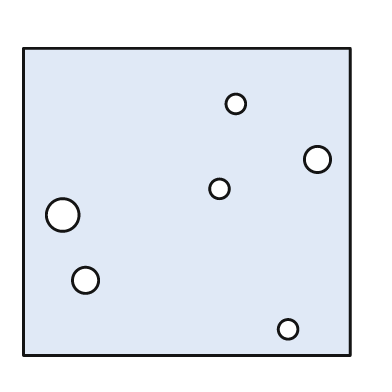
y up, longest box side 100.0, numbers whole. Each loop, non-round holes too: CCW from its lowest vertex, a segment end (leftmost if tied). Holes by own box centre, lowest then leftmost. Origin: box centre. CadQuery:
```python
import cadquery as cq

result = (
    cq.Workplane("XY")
    .moveTo(-50.0, -47.0)
    .lineTo(50.0, -47.0)
    .lineTo(50.0, 47.0)
    .lineTo(-50.0, 47.0)
    .close()
    .moveTo(31.0, -39.0)
    .circle(3.0)
    .moveTo(-31.0, -24.0)
    .circle(4.0)
    .moveTo(-38.0, -4.0)
    .circle(5.0)
    .moveTo(10.0, 4.0)
    .circle(3.0)
    .moveTo(40.0, 13.0)
    .circle(4.0)
    .moveTo(15.0, 30.0)
    .circle(3.0)
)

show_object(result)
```